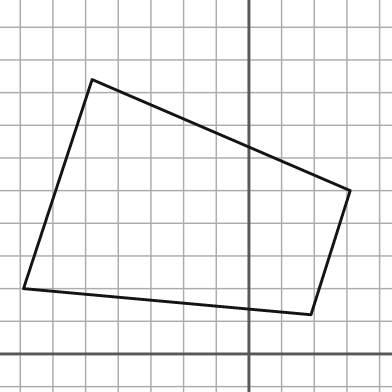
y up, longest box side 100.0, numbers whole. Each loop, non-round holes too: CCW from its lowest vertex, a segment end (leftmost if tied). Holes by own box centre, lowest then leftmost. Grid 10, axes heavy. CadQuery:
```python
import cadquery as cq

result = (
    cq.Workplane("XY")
    .moveTo(19.0, 12.0)
    .lineTo(31.0, 50.0)
    .lineTo(-48.0, 84.0)
    .lineTo(-69.0, 20.0)
    .close()
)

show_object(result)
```